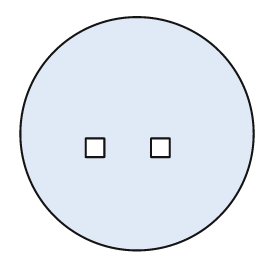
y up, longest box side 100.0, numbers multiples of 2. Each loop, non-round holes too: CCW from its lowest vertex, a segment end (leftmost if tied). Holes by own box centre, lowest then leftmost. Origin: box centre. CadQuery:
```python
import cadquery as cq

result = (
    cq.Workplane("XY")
    .moveTo(0.0, 0.0)
    .circle(50.0)
    .moveTo(-22.0, -10.0)
    .lineTo(-14.0, -10.0)
    .lineTo(-14.0, -2.0)
    .lineTo(-22.0, -2.0)
    .close()
    .moveTo(6.0, -10.0)
    .lineTo(14.0, -10.0)
    .lineTo(14.0, -2.0)
    .lineTo(6.0, -2.0)
    .close()
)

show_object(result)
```